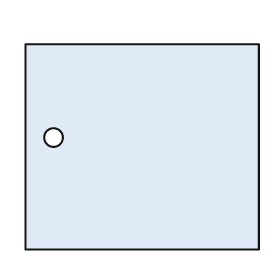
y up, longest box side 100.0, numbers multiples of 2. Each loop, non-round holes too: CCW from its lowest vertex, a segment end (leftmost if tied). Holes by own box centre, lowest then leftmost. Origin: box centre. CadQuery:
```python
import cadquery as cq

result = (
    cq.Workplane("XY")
    .moveTo(-50.0, -44.0)
    .lineTo(50.0, -44.0)
    .lineTo(50.0, 44.0)
    .lineTo(-50.0, 44.0)
    .close()
    .moveTo(-38.0, 4.0)
    .circle(4.0)
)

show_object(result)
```